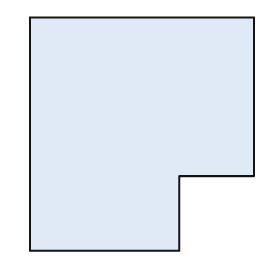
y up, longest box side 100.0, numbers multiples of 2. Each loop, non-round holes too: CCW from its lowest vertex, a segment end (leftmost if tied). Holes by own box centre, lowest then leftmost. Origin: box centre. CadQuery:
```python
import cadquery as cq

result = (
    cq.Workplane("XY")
    .moveTo(-48.0, -50.0)
    .lineTo(16.0, -50.0)
    .lineTo(16.0, -18.0)
    .lineTo(48.0, -18.0)
    .lineTo(48.0, 50.0)
    .lineTo(-48.0, 50.0)
    .close()
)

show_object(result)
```